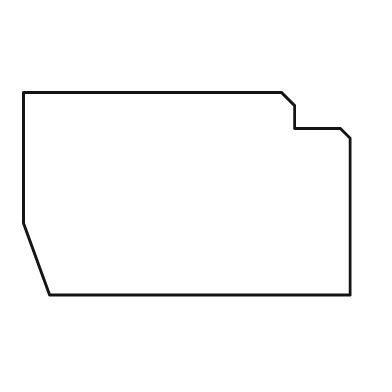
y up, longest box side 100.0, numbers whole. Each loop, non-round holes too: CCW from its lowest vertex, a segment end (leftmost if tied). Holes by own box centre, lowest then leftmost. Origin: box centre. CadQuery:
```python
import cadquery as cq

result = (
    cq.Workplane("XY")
    .moveTo(-42.0, -31.0)
    .lineTo(50.0, -31.0)
    .lineTo(50.0, 17.0)
    .lineTo(47.0, 20.0)
    .lineTo(33.0, 20.0)
    .lineTo(33.0, 27.0)
    .lineTo(29.0, 31.0)
    .lineTo(-50.0, 31.0)
    .lineTo(-50.0, -9.0)
    .close()
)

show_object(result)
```